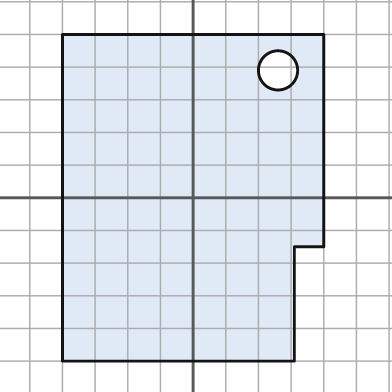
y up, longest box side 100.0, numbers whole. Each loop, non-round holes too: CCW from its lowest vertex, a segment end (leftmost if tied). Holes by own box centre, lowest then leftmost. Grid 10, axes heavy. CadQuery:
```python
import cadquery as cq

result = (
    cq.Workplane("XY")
    .moveTo(-40.0, -50.0)
    .lineTo(31.0, -50.0)
    .lineTo(31.0, -15.0)
    .lineTo(40.0, -15.0)
    .lineTo(40.0, 50.0)
    .lineTo(-40.0, 50.0)
    .close()
    .moveTo(26.0, 39.0)
    .circle(6.0)
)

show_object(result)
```